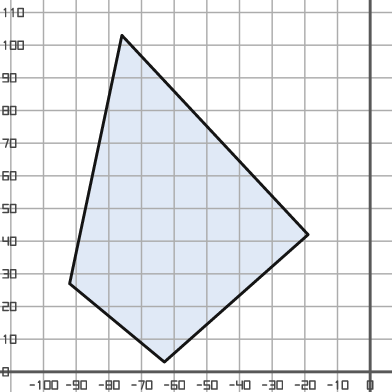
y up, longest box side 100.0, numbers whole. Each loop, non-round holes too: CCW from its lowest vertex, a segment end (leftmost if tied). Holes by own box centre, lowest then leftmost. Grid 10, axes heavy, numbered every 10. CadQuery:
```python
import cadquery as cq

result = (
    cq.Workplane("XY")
    .moveTo(-63.0, 3.0)
    .lineTo(-19.0, 42.0)
    .lineTo(-76.0, 103.0)
    .lineTo(-92.0, 27.0)
    .close()
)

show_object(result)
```